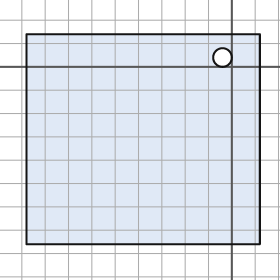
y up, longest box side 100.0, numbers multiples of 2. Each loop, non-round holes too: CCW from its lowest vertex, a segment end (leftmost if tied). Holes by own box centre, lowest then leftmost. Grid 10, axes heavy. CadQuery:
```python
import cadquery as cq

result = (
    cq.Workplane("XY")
    .moveTo(-88.0, -76.0)
    .lineTo(12.0, -76.0)
    .lineTo(12.0, 14.0)
    .lineTo(-88.0, 14.0)
    .close()
    .moveTo(-4.0, 4.0)
    .circle(4.0)
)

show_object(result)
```